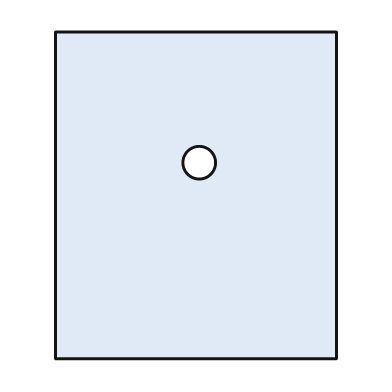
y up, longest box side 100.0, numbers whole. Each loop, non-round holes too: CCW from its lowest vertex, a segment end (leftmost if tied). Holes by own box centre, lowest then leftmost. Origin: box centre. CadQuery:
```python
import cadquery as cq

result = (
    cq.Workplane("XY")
    .moveTo(-43.0, -50.0)
    .lineTo(43.0, -50.0)
    .lineTo(43.0, 50.0)
    .lineTo(-43.0, 50.0)
    .close()
    .moveTo(1.0, 10.0)
    .circle(5.0)
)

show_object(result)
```